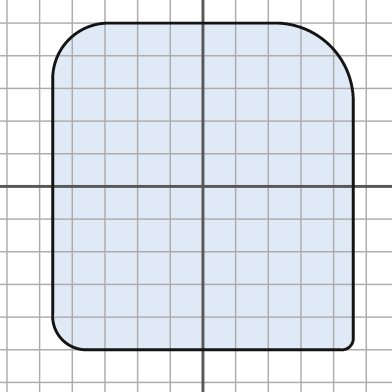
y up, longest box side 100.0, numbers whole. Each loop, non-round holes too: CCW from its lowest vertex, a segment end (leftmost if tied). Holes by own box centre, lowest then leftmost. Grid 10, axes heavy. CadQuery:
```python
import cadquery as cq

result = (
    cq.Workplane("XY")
    .moveTo(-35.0, -50.0)
    .lineTo(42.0, -50.0)
    .threePointArc((45.0, -49.0), (46.0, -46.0))
    .lineTo(46.0, 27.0)
    .threePointArc((39.0, 43.0), (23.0, 50.0))
    .lineTo(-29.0, 50.0)
    .threePointArc((-41.0, 45.0), (-46.0, 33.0))
    .lineTo(-46.0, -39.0)
    .threePointArc((-43.0, -47.0), (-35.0, -50.0))
    .close()
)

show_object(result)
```